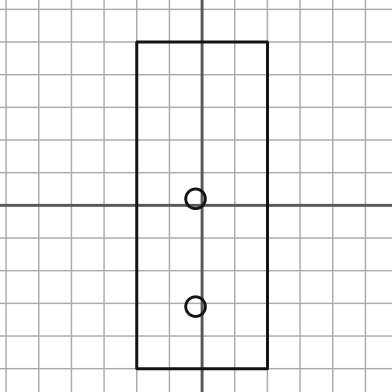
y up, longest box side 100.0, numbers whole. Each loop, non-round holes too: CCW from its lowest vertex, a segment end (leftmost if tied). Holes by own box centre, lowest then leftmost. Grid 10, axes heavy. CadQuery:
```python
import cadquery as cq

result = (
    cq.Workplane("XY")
    .moveTo(-20.0, -50.0)
    .lineTo(20.0, -50.0)
    .lineTo(20.0, 50.0)
    .lineTo(-20.0, 50.0)
    .close()
    .moveTo(-2.0, -31.0)
    .circle(3.0)
    .moveTo(-2.0, 2.0)
    .circle(3.0)
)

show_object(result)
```